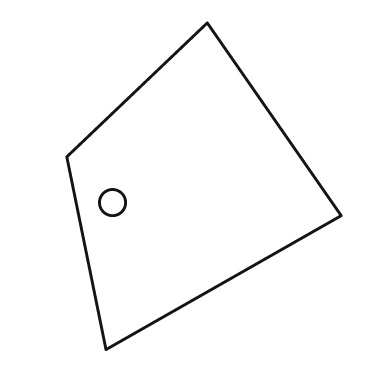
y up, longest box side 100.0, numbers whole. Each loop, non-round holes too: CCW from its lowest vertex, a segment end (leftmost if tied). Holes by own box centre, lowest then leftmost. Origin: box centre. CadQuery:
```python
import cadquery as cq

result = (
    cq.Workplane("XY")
    .moveTo(-30.0, -50.0)
    .lineTo(42.0, -9.0)
    .lineTo(1.0, 50.0)
    .lineTo(-42.0, 9.0)
    .close()
    .moveTo(-28.0, -5.0)
    .circle(4.0)
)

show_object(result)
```